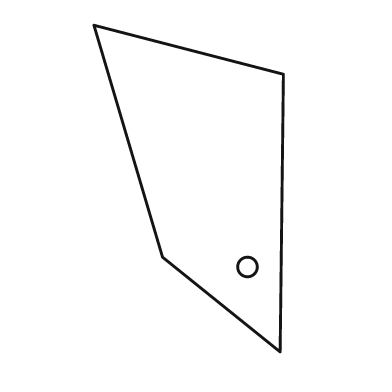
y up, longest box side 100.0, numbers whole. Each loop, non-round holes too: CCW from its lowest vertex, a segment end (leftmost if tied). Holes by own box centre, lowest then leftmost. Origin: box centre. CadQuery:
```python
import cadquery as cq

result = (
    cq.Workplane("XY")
    .moveTo(28.0, -50.0)
    .lineTo(29.0, 35.0)
    .lineTo(-29.0, 50.0)
    .lineTo(-8.0, -21.0)
    .close()
    .moveTo(18.0, -24.0)
    .circle(3.0)
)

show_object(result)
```